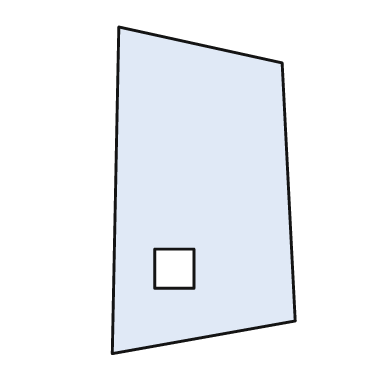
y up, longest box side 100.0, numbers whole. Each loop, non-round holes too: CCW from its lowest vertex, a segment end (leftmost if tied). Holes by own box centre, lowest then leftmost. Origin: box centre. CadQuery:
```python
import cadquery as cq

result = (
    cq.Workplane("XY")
    .moveTo(-28.0, -50.0)
    .lineTo(28.0, -40.0)
    .lineTo(24.0, 39.0)
    .lineTo(-26.0, 50.0)
    .close()
    .moveTo(-15.0, -30.0)
    .lineTo(-3.0, -30.0)
    .lineTo(-3.0, -18.0)
    .lineTo(-15.0, -18.0)
    .close()
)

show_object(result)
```